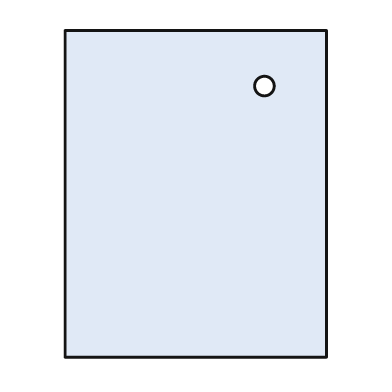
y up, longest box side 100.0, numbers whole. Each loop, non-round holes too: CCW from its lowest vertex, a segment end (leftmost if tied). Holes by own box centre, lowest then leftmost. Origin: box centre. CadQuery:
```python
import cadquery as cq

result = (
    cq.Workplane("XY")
    .moveTo(-40.0, -50.0)
    .lineTo(40.0, -50.0)
    .lineTo(40.0, 50.0)
    .lineTo(-40.0, 50.0)
    .close()
    .moveTo(21.0, 33.0)
    .circle(3.0)
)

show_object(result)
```